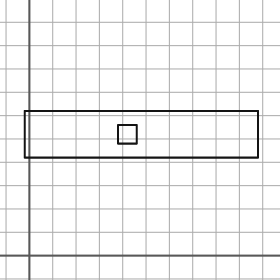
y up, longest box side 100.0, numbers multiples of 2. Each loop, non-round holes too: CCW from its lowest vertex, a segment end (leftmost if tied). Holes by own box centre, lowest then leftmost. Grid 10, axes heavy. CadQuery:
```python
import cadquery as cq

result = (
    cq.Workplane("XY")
    .moveTo(-2.0, 42.0)
    .lineTo(98.0, 42.0)
    .lineTo(98.0, 62.0)
    .lineTo(-2.0, 62.0)
    .close()
    .moveTo(38.0, 48.0)
    .lineTo(46.0, 48.0)
    .lineTo(46.0, 56.0)
    .lineTo(38.0, 56.0)
    .close()
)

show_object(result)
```